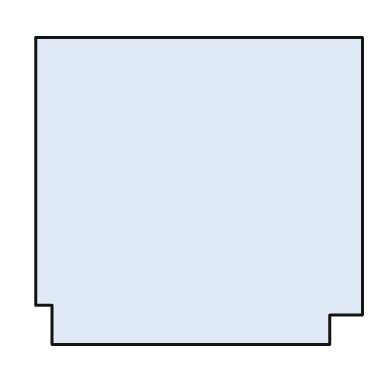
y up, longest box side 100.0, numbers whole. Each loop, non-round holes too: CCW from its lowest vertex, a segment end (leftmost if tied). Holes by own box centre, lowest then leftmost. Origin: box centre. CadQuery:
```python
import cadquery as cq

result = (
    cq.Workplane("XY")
    .moveTo(-45.0, -47.0)
    .lineTo(40.0, -47.0)
    .lineTo(40.0, -38.0)
    .lineTo(50.0, -38.0)
    .lineTo(50.0, 47.0)
    .lineTo(-50.0, 47.0)
    .lineTo(-50.0, -35.0)
    .lineTo(-45.0, -35.0)
    .close()
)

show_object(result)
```